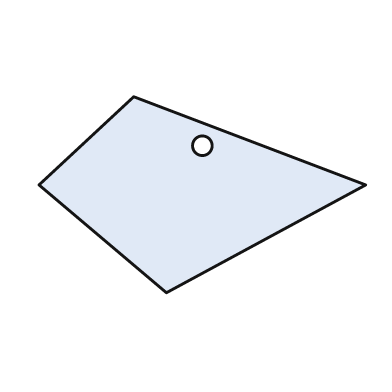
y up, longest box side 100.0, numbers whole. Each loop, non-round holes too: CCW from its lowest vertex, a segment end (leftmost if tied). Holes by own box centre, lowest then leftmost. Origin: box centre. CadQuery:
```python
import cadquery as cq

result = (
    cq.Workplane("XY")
    .moveTo(-11.0, -30.0)
    .lineTo(50.0, 3.0)
    .lineTo(-21.0, 30.0)
    .lineTo(-50.0, 3.0)
    .close()
    .moveTo(0.0, 15.0)
    .circle(3.0)
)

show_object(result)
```